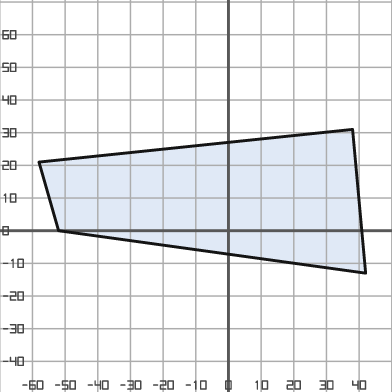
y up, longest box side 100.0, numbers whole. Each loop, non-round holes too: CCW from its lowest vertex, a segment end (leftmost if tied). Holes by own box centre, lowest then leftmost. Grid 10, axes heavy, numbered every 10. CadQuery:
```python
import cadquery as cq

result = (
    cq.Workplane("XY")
    .moveTo(42.0, -13.0)
    .lineTo(38.0, 31.0)
    .lineTo(-58.0, 21.0)
    .lineTo(-52.0, 0.0)
    .close()
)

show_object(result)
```